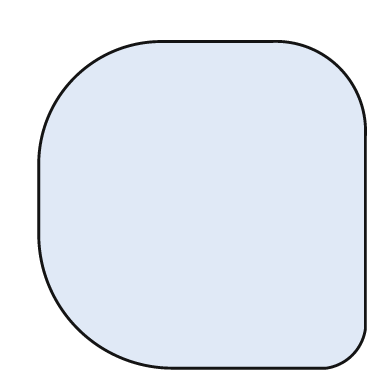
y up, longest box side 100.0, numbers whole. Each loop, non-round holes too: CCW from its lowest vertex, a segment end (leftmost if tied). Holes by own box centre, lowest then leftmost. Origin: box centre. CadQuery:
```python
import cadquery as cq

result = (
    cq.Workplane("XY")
    .moveTo(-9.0, -50.0)
    .lineTo(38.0, -50.0)
    .threePointArc((46.0, -46.0), (50.0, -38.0))
    .lineTo(50.0, 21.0)
    .threePointArc((42.0, 42.0), (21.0, 50.0))
    .lineTo(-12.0, 50.0)
    .threePointArc((-39.0, 39.0), (-50.0, 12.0))
    .lineTo(-50.0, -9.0)
    .threePointArc((-38.0, -38.0), (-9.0, -50.0))
    .close()
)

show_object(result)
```